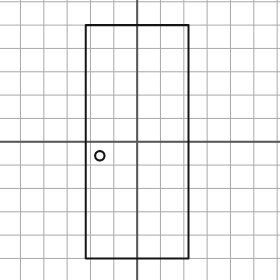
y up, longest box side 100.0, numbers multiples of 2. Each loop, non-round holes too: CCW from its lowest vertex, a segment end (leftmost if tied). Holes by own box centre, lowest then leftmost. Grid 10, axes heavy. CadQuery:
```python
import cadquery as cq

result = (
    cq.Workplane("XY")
    .moveTo(-22.0, -50.0)
    .lineTo(22.0, -50.0)
    .lineTo(22.0, 50.0)
    .lineTo(-22.0, 50.0)
    .close()
    .moveTo(-16.0, -6.0)
    .circle(2.0)
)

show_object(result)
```